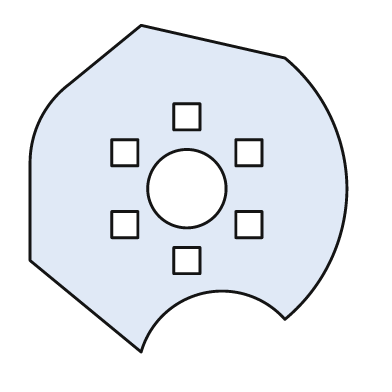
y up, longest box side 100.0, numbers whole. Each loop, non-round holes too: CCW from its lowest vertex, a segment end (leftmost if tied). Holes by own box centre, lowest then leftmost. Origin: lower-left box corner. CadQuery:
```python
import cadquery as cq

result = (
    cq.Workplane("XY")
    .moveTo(34.0, 0.0)
    .threePointArc((53.0, 18.0), (78.0, 10.0))
    .threePointArc((92.0, 28.0), (97.0, 50.0))
    .threePointArc((92.0, 72.0), (78.0, 90.0))
    .lineTo(34.0, 100.0)
    .lineTo(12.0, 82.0)
    .threePointArc((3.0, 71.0), (0.0, 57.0))
    .lineTo(0.0, 28.0)
    .close()
    .moveTo(44.0, 24.0)
    .lineTo(52.0, 24.0)
    .lineTo(52.0, 32.0)
    .lineTo(44.0, 32.0)
    .close()
    .moveTo(25.0, 35.0)
    .lineTo(33.0, 35.0)
    .lineTo(33.0, 43.0)
    .lineTo(25.0, 43.0)
    .close()
    .moveTo(63.0, 35.0)
    .lineTo(71.0, 35.0)
    .lineTo(71.0, 43.0)
    .lineTo(63.0, 43.0)
    .close()
    .moveTo(48.0, 50.0)
    .circle(12.0)
    .moveTo(25.0, 57.0)
    .lineTo(33.0, 57.0)
    .lineTo(33.0, 65.0)
    .lineTo(25.0, 65.0)
    .close()
    .moveTo(63.0, 57.0)
    .lineTo(71.0, 57.0)
    .lineTo(71.0, 65.0)
    .lineTo(63.0, 65.0)
    .close()
    .moveTo(44.0, 68.0)
    .lineTo(52.0, 68.0)
    .lineTo(52.0, 76.0)
    .lineTo(44.0, 76.0)
    .close()
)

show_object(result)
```